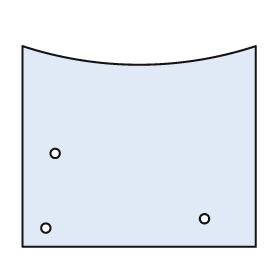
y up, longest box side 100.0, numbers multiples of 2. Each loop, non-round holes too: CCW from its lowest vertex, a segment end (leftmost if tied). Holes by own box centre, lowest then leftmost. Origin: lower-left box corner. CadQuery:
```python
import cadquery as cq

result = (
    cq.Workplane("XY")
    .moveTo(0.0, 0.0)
    .lineTo(100.0, 0.0)
    .lineTo(100.0, 86.0)
    .threePointArc((50.0, 78.0), (0.0, 86.0))
    .close()
    .moveTo(10.0, 8.0)
    .circle(2.0)
    .moveTo(78.0, 12.0)
    .circle(2.0)
    .moveTo(14.0, 40.0)
    .circle(2.0)
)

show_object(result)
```